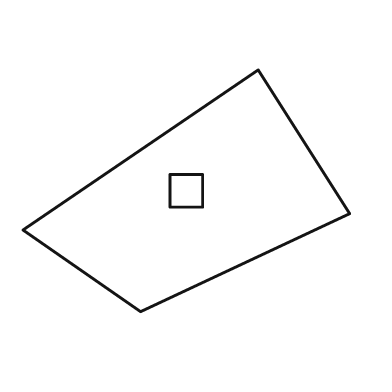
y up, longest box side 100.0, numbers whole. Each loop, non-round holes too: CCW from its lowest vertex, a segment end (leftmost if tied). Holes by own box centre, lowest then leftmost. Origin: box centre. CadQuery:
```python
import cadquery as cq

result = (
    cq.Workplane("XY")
    .moveTo(-14.0, -37.0)
    .lineTo(50.0, -7.0)
    .lineTo(22.0, 37.0)
    .lineTo(-50.0, -12.0)
    .close()
    .moveTo(-5.0, -5.0)
    .lineTo(5.0, -5.0)
    .lineTo(5.0, 5.0)
    .lineTo(-5.0, 5.0)
    .close()
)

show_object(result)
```